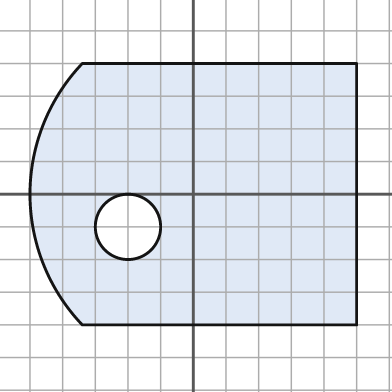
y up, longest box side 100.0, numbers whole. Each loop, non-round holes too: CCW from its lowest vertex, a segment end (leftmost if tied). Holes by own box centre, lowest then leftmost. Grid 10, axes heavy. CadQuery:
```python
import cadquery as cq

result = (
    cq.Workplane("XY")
    .moveTo(-34.0, -40.0)
    .lineTo(50.0, -40.0)
    .lineTo(50.0, 40.0)
    .lineTo(-34.0, 40.0)
    .threePointArc((-50.0, 0.0), (-34.0, -40.0))
    .close()
    .moveTo(-20.0, -10.0)
    .circle(10.0)
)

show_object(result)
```